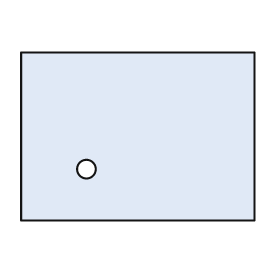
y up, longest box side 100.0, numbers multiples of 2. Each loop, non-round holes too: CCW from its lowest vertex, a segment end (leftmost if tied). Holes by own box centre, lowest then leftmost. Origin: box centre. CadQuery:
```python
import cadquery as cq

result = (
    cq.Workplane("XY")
    .moveTo(-50.0, -36.0)
    .lineTo(50.0, -36.0)
    .lineTo(50.0, 36.0)
    .lineTo(-50.0, 36.0)
    .close()
    .moveTo(-22.0, -14.0)
    .circle(4.0)
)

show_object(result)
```